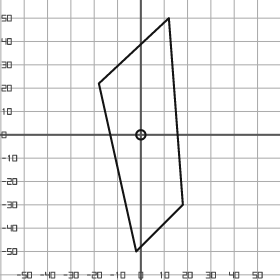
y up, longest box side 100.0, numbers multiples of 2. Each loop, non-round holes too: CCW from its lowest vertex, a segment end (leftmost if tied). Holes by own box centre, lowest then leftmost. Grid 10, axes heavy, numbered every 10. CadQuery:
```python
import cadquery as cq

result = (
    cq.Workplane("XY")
    .moveTo(-2.0, -50.0)
    .lineTo(18.0, -30.0)
    .lineTo(12.0, 50.0)
    .lineTo(-18.0, 22.0)
    .close()
    .moveTo(0.0, 0.0)
    .circle(2.0)
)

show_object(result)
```